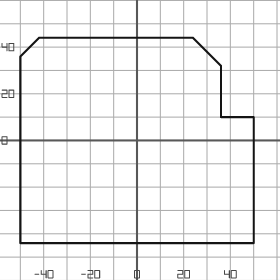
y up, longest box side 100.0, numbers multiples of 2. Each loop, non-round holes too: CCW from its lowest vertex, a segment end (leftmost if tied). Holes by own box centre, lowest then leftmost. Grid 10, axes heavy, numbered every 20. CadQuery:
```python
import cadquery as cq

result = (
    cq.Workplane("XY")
    .moveTo(-50.0, -44.0)
    .lineTo(50.0, -44.0)
    .lineTo(50.0, 10.0)
    .lineTo(36.0, 10.0)
    .lineTo(36.0, 32.0)
    .lineTo(24.0, 44.0)
    .lineTo(-42.0, 44.0)
    .lineTo(-50.0, 36.0)
    .close()
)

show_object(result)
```